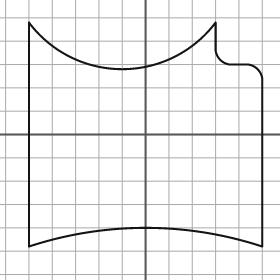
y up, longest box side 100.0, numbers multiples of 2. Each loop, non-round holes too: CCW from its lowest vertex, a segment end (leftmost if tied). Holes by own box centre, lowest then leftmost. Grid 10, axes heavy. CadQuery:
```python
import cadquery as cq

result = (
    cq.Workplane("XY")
    .moveTo(-50.0, -48.0)
    .threePointArc((0.0, -40.0), (50.0, -48.0))
    .lineTo(50.0, 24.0)
    .threePointArc((48.0, 28.0), (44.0, 30.0))
    .lineTo(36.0, 30.0)
    .threePointArc((32.0, 32.0), (30.0, 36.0))
    .lineTo(30.0, 48.0)
    .threePointArc((-10.0, 28.0), (-50.0, 48.0))
    .close()
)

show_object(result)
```